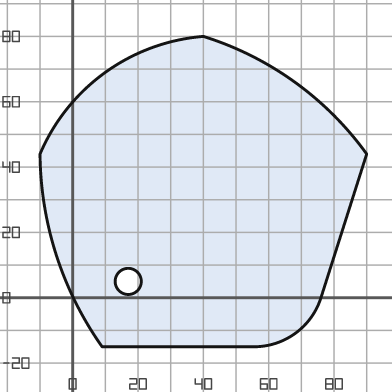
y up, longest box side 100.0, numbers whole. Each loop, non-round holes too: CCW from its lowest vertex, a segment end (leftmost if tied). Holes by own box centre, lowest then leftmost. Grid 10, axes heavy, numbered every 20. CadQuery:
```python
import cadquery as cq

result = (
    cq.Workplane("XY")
    .moveTo(9.0, -15.0)
    .lineTo(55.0, -15.0)
    .threePointArc((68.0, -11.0), (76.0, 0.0))
    .lineTo(90.0, 44.0)
    .threePointArc((68.0, 66.0), (40.0, 80.0))
    .threePointArc((10.0, 69.0), (-10.0, 44.0))
    .threePointArc((-5.0, 13.0), (9.0, -15.0))
    .close()
    .moveTo(17.0, 5.0)
    .circle(4.0)
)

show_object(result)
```